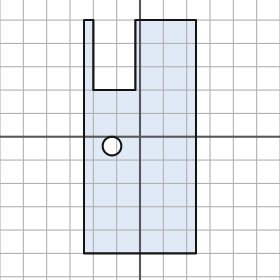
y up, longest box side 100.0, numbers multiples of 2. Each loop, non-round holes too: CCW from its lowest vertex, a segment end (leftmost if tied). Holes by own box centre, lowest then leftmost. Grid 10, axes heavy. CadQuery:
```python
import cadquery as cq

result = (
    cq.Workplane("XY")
    .moveTo(-24.0, -50.0)
    .lineTo(24.0, -50.0)
    .lineTo(24.0, 50.0)
    .lineTo(-2.0, 50.0)
    .lineTo(-2.0, 20.0)
    .lineTo(-20.0, 20.0)
    .lineTo(-20.0, 50.0)
    .lineTo(-24.0, 50.0)
    .close()
    .moveTo(-12.0, -4.0)
    .circle(4.0)
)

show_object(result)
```